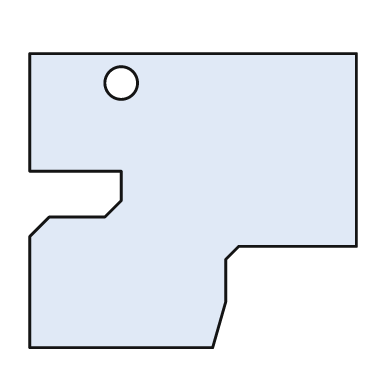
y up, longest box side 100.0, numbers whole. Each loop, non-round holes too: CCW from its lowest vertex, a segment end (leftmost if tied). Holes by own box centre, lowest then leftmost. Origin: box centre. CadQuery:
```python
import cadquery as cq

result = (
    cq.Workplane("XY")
    .moveTo(-50.0, -45.0)
    .lineTo(6.0, -45.0)
    .lineTo(10.0, -31.0)
    .lineTo(10.0, -18.0)
    .lineTo(14.0, -14.0)
    .lineTo(50.0, -14.0)
    .lineTo(50.0, 45.0)
    .lineTo(-50.0, 45.0)
    .lineTo(-50.0, 9.0)
    .lineTo(-22.0, 9.0)
    .lineTo(-22.0, 0.0)
    .lineTo(-27.0, -5.0)
    .lineTo(-44.0, -5.0)
    .lineTo(-50.0, -11.0)
    .close()
    .moveTo(-22.0, 36.0)
    .circle(5.0)
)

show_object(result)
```